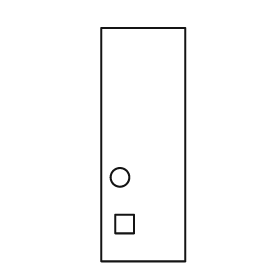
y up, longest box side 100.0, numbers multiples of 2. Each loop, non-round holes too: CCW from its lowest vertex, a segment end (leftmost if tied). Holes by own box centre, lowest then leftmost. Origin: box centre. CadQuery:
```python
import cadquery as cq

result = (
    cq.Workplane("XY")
    .moveTo(-18.0, -50.0)
    .lineTo(18.0, -50.0)
    .lineTo(18.0, 50.0)
    .lineTo(-18.0, 50.0)
    .close()
    .moveTo(-12.0, -38.0)
    .lineTo(-4.0, -38.0)
    .lineTo(-4.0, -30.0)
    .lineTo(-12.0, -30.0)
    .close()
    .moveTo(-10.0, -14.0)
    .circle(4.0)
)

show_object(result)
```